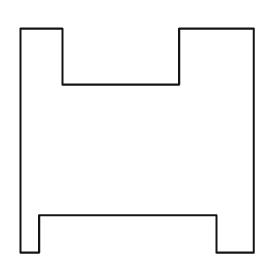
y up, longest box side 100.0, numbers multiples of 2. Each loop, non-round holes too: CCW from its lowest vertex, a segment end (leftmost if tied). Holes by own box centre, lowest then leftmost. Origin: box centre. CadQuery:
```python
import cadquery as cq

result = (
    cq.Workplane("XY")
    .moveTo(-50.0, -48.0)
    .lineTo(-42.0, -48.0)
    .lineTo(-42.0, -32.0)
    .lineTo(34.0, -32.0)
    .lineTo(34.0, -48.0)
    .lineTo(50.0, -48.0)
    .lineTo(50.0, 48.0)
    .lineTo(18.0, 48.0)
    .lineTo(18.0, 24.0)
    .lineTo(-32.0, 24.0)
    .lineTo(-32.0, 48.0)
    .lineTo(-50.0, 48.0)
    .close()
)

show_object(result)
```